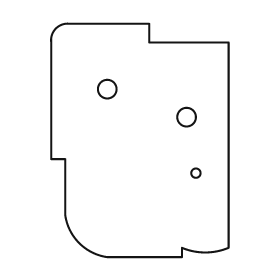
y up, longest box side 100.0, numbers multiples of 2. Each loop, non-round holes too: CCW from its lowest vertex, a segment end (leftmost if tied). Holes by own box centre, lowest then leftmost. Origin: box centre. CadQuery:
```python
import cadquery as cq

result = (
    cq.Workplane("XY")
    .moveTo(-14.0, -50.0)
    .lineTo(18.0, -50.0)
    .lineTo(18.0, -46.0)
    .threePointArc((28.0, -48.0), (38.0, -46.0))
    .lineTo(38.0, 42.0)
    .lineTo(4.0, 42.0)
    .lineTo(4.0, 50.0)
    .lineTo(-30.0, 50.0)
    .threePointArc((-36.0, 48.0), (-38.0, 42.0))
    .lineTo(-38.0, -8.0)
    .lineTo(-32.0, -8.0)
    .lineTo(-32.0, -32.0)
    .threePointArc((-26.0, -44.0), (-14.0, -50.0))
    .close()
    .moveTo(24.0, -14.0)
    .circle(2.0)
    .moveTo(20.0, 10.0)
    .circle(4.0)
    .moveTo(-14.0, 22.0)
    .circle(4.0)
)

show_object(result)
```